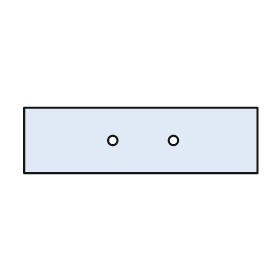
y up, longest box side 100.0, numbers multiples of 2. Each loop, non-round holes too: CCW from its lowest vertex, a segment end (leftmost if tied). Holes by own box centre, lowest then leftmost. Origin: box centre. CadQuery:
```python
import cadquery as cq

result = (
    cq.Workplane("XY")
    .moveTo(-50.0, -14.0)
    .lineTo(50.0, -14.0)
    .lineTo(50.0, 14.0)
    .lineTo(-50.0, 14.0)
    .close()
    .moveTo(-12.0, 0.0)
    .circle(2.0)
    .moveTo(14.0, 0.0)
    .circle(2.0)
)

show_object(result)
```